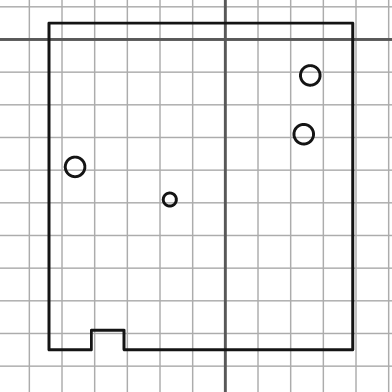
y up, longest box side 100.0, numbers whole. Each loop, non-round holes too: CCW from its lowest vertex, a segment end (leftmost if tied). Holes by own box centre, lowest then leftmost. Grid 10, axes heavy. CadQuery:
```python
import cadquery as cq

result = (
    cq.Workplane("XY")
    .moveTo(-54.0, -95.0)
    .lineTo(-41.0, -95.0)
    .lineTo(-41.0, -89.0)
    .lineTo(-31.0, -89.0)
    .lineTo(-31.0, -95.0)
    .lineTo(39.0, -95.0)
    .lineTo(39.0, 5.0)
    .lineTo(-54.0, 5.0)
    .close()
    .moveTo(-17.0, -49.0)
    .circle(2.0)
    .moveTo(-46.0, -39.0)
    .circle(3.0)
    .moveTo(24.0, -29.0)
    .circle(3.0)
    .moveTo(26.0, -11.0)
    .circle(3.0)
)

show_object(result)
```